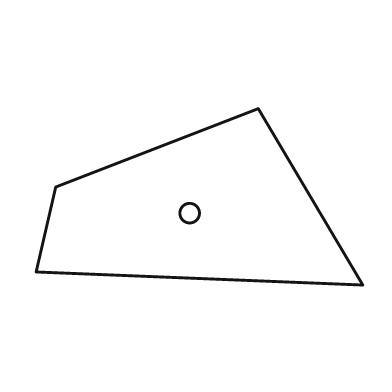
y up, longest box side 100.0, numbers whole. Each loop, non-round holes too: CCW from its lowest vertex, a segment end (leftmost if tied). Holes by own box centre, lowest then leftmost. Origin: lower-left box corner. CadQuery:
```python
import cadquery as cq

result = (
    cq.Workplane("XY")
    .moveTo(100.0, 0.0)
    .lineTo(68.0, 54.0)
    .lineTo(6.0, 30.0)
    .lineTo(0.0, 4.0)
    .close()
    .moveTo(47.0, 22.0)
    .circle(3.0)
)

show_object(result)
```